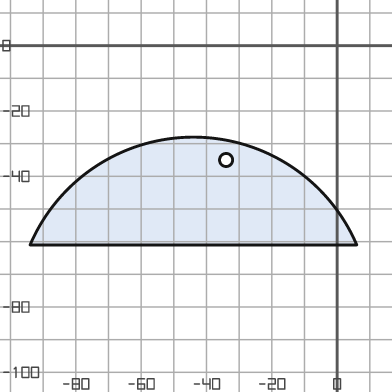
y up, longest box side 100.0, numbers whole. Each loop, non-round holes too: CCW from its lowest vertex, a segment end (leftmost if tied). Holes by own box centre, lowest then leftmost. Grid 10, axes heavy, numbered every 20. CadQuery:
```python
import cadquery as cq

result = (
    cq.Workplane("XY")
    .moveTo(-94.0, -61.0)
    .lineTo(6.0, -61.0)
    .threePointArc((-44.0, -28.0), (-94.0, -61.0))
    .close()
    .moveTo(-34.0, -35.0)
    .circle(2.0)
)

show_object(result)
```